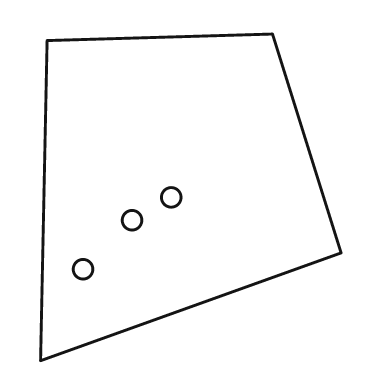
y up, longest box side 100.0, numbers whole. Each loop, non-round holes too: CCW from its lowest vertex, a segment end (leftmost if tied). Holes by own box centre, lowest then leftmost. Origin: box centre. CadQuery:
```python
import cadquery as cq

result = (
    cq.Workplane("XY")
    .moveTo(-46.0, -50.0)
    .lineTo(46.0, -17.0)
    .lineTo(25.0, 50.0)
    .lineTo(-44.0, 48.0)
    .close()
    .moveTo(-33.0, -22.0)
    .circle(3.0)
    .moveTo(-18.0, -7.0)
    .circle(3.0)
    .moveTo(-6.0, 0.0)
    .circle(3.0)
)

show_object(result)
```